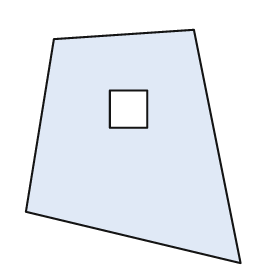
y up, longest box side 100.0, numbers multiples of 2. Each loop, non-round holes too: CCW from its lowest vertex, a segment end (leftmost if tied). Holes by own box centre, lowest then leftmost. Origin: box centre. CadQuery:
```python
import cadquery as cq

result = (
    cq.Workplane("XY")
    .moveTo(46.0, -50.0)
    .lineTo(26.0, 50.0)
    .lineTo(-34.0, 46.0)
    .lineTo(-46.0, -28.0)
    .close()
    .moveTo(-10.0, 8.0)
    .lineTo(6.0, 8.0)
    .lineTo(6.0, 24.0)
    .lineTo(-10.0, 24.0)
    .close()
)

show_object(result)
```